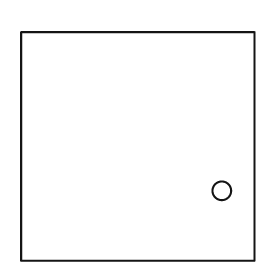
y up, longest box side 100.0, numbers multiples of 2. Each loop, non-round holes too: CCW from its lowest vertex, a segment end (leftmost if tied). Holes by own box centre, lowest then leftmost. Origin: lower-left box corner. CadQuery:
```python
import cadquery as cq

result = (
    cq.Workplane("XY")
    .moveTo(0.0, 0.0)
    .lineTo(100.0, 0.0)
    .lineTo(100.0, 98.0)
    .lineTo(0.0, 98.0)
    .close()
    .moveTo(86.0, 30.0)
    .circle(4.0)
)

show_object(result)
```